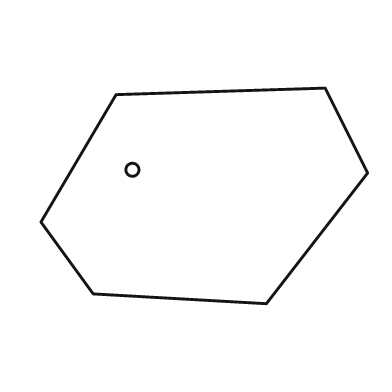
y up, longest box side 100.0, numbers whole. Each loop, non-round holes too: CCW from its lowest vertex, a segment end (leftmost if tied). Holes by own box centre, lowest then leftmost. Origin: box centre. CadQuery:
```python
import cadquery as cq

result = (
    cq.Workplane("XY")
    .moveTo(19.0, -33.0)
    .lineTo(50.0, 7.0)
    .lineTo(37.0, 33.0)
    .lineTo(-27.0, 31.0)
    .lineTo(-50.0, -8.0)
    .lineTo(-34.0, -30.0)
    .close()
    .moveTo(-22.0, 8.0)
    .circle(2.0)
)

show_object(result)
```